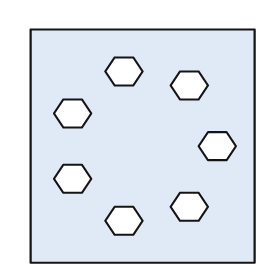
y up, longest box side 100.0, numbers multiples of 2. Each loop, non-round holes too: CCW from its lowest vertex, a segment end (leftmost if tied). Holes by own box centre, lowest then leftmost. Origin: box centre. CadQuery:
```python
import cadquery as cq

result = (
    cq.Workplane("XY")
    .moveTo(-48.0, -50.0)
    .lineTo(48.0, -50.0)
    .lineTo(48.0, 50.0)
    .lineTo(-48.0, 50.0)
    .close()
    .moveTo(-12.0, -38.0)
    .lineTo(-4.0, -38.0)
    .lineTo(0.0, -32.0)
    .lineTo(-4.0, -26.0)
    .lineTo(-12.0, -26.0)
    .lineTo(-16.0, -32.0)
    .close()
    .moveTo(16.0, -32.0)
    .lineTo(24.0, -32.0)
    .lineTo(28.0, -26.0)
    .lineTo(24.0, -20.0)
    .lineTo(16.0, -20.0)
    .lineTo(12.0, -26.0)
    .close()
    .moveTo(-34.0, -20.0)
    .lineTo(-26.0, -20.0)
    .lineTo(-22.0, -14.0)
    .lineTo(-26.0, -8.0)
    .lineTo(-34.0, -8.0)
    .lineTo(-38.0, -14.0)
    .close()
    .moveTo(28.0, -6.0)
    .lineTo(36.0, -6.0)
    .lineTo(40.0, 0.0)
    .lineTo(36.0, 6.0)
    .lineTo(28.0, 6.0)
    .lineTo(24.0, 0.0)
    .close()
    .moveTo(-34.0, 8.0)
    .lineTo(-26.0, 8.0)
    .lineTo(-22.0, 14.0)
    .lineTo(-26.0, 20.0)
    .lineTo(-34.0, 20.0)
    .lineTo(-38.0, 14.0)
    .close()
    .moveTo(16.0, 20.0)
    .lineTo(24.0, 20.0)
    .lineTo(28.0, 26.0)
    .lineTo(24.0, 32.0)
    .lineTo(16.0, 32.0)
    .lineTo(12.0, 26.0)
    .close()
    .moveTo(-12.0, 26.0)
    .lineTo(-4.0, 26.0)
    .lineTo(0.0, 32.0)
    .lineTo(-4.0, 38.0)
    .lineTo(-12.0, 38.0)
    .lineTo(-16.0, 32.0)
    .close()
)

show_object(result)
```